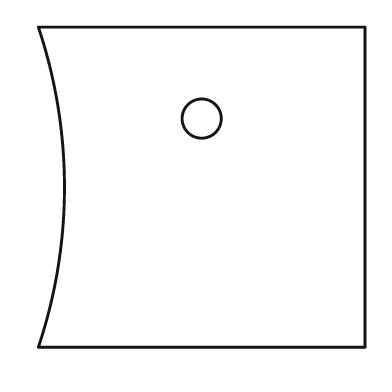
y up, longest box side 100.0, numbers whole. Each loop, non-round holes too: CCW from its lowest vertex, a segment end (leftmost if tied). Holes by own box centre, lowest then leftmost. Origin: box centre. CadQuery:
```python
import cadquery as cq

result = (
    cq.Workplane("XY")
    .moveTo(-50.0, -49.0)
    .lineTo(50.0, -49.0)
    .lineTo(50.0, 49.0)
    .lineTo(-50.0, 49.0)
    .threePointArc((-42.0, 0.0), (-50.0, -49.0))
    .close()
    .moveTo(0.0, 21.0)
    .circle(6.0)
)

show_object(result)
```